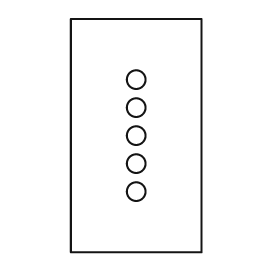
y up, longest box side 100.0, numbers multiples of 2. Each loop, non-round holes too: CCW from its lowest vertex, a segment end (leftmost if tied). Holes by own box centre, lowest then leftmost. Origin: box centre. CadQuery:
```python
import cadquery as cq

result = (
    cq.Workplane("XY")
    .moveTo(-28.0, -50.0)
    .lineTo(28.0, -50.0)
    .lineTo(28.0, 50.0)
    .lineTo(-28.0, 50.0)
    .close()
    .moveTo(0.0, -24.0)
    .circle(4.0)
    .moveTo(0.0, -12.0)
    .circle(4.0)
    .moveTo(0.0, 0.0)
    .circle(4.0)
    .moveTo(0.0, 12.0)
    .circle(4.0)
    .moveTo(0.0, 24.0)
    .circle(4.0)
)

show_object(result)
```